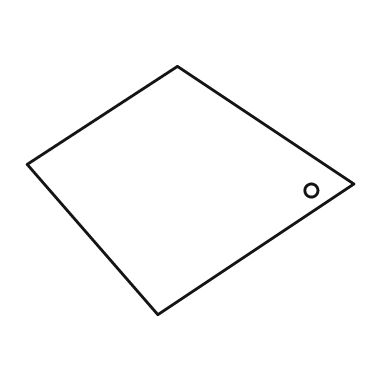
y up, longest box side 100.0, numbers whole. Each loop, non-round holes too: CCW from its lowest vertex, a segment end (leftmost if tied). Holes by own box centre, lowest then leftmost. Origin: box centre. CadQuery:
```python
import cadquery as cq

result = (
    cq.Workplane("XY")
    .moveTo(-10.0, -38.0)
    .lineTo(50.0, 2.0)
    .lineTo(-4.0, 38.0)
    .lineTo(-50.0, 8.0)
    .close()
    .moveTo(37.0, 0.0)
    .circle(2.0)
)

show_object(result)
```